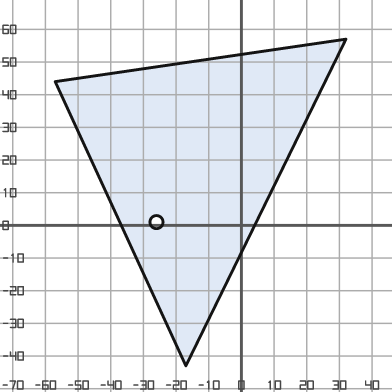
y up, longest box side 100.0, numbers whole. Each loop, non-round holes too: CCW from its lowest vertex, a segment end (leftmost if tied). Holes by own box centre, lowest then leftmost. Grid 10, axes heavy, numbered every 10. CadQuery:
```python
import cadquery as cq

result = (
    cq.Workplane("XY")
    .moveTo(-17.0, -43.0)
    .lineTo(32.0, 57.0)
    .lineTo(-57.0, 44.0)
    .close()
    .moveTo(-26.0, 1.0)
    .circle(2.0)
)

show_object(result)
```